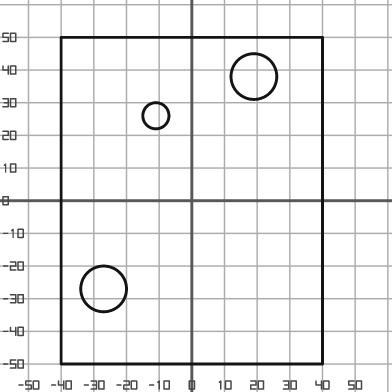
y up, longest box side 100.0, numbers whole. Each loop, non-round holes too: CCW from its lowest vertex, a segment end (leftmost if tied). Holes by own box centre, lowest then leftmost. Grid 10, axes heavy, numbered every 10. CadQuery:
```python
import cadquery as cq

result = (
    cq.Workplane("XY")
    .moveTo(-40.0, -50.0)
    .lineTo(40.0, -50.0)
    .lineTo(40.0, 50.0)
    .lineTo(-40.0, 50.0)
    .close()
    .moveTo(-27.0, -27.0)
    .circle(7.0)
    .moveTo(-11.0, 26.0)
    .circle(4.0)
    .moveTo(19.0, 38.0)
    .circle(7.0)
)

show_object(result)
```